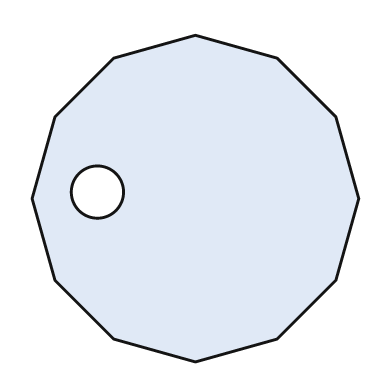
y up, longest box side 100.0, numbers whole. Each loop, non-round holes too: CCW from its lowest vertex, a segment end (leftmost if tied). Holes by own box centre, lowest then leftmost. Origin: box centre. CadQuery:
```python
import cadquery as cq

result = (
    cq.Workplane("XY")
    .moveTo(0.0, -50.0)
    .lineTo(25.0, -43.0)
    .lineTo(43.0, -25.0)
    .lineTo(50.0, 0.0)
    .lineTo(43.0, 25.0)
    .lineTo(25.0, 43.0)
    .lineTo(0.0, 50.0)
    .lineTo(-25.0, 43.0)
    .lineTo(-43.0, 25.0)
    .lineTo(-50.0, 0.0)
    .lineTo(-43.0, -25.0)
    .lineTo(-25.0, -43.0)
    .close()
    .moveTo(-30.0, 2.0)
    .circle(8.0)
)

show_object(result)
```